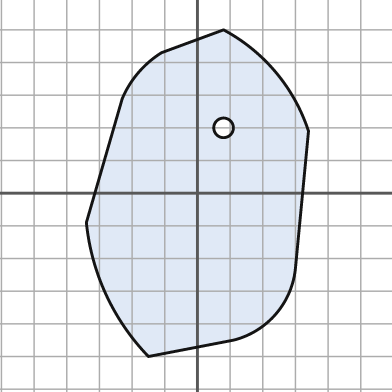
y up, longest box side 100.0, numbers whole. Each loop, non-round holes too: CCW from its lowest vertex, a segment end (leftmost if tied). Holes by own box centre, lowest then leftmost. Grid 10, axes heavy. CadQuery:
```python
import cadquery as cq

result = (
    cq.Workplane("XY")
    .moveTo(-15.0, -50.0)
    .lineTo(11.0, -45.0)
    .threePointArc((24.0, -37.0), (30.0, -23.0))
    .lineTo(34.0, 19.0)
    .threePointArc((24.0, 37.0), (8.0, 50.0))
    .lineTo(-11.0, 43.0)
    .threePointArc((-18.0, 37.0), (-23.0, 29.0))
    .lineTo(-34.0, -9.0)
    .threePointArc((-28.0, -31.0), (-15.0, -50.0))
    .close()
    .moveTo(8.0, 20.0)
    .circle(3.0)
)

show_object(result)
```